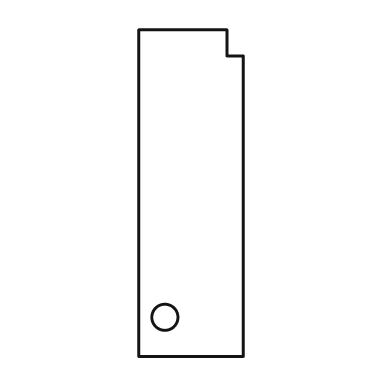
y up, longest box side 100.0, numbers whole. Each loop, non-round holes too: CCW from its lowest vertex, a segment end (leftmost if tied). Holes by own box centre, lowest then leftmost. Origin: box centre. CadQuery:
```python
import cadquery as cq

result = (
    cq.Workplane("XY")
    .moveTo(-16.0, -50.0)
    .lineTo(16.0, -50.0)
    .lineTo(16.0, 42.0)
    .lineTo(11.0, 42.0)
    .lineTo(11.0, 50.0)
    .lineTo(-16.0, 50.0)
    .close()
    .moveTo(-8.0, -38.0)
    .circle(4.0)
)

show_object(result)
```